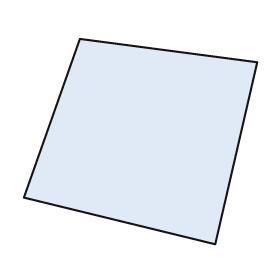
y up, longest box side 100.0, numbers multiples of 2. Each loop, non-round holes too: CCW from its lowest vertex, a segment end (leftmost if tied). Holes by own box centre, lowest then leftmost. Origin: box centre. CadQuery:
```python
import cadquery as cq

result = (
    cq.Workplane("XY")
    .moveTo(32.0, -44.0)
    .lineTo(50.0, 34.0)
    .lineTo(-26.0, 44.0)
    .lineTo(-50.0, -24.0)
    .close()
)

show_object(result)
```